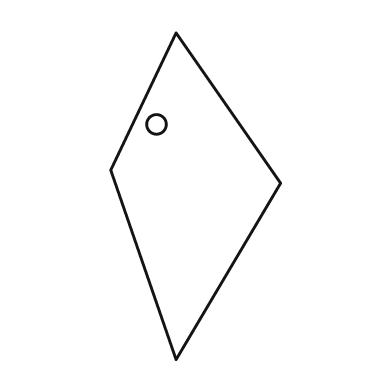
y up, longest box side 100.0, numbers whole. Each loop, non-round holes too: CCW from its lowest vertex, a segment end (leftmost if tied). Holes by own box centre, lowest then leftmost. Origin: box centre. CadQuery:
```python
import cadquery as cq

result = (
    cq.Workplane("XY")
    .moveTo(-6.0, -50.0)
    .lineTo(26.0, 4.0)
    .lineTo(-6.0, 50.0)
    .lineTo(-26.0, 8.0)
    .close()
    .moveTo(-12.0, 22.0)
    .circle(3.0)
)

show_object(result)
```